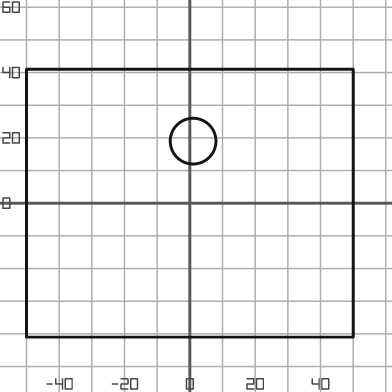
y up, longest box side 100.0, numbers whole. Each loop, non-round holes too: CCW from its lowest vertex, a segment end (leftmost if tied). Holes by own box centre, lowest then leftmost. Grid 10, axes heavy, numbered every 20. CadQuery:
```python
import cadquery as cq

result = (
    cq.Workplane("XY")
    .moveTo(-50.0, -41.0)
    .lineTo(50.0, -41.0)
    .lineTo(50.0, 41.0)
    .lineTo(-50.0, 41.0)
    .close()
    .moveTo(1.0, 19.0)
    .circle(7.0)
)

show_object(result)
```